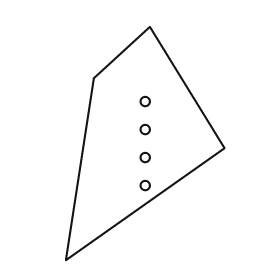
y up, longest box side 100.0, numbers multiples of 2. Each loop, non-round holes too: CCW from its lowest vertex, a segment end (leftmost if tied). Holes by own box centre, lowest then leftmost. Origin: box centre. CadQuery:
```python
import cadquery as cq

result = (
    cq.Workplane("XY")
    .moveTo(-34.0, -50.0)
    .lineTo(34.0, -2.0)
    .lineTo(2.0, 50.0)
    .lineTo(-22.0, 28.0)
    .close()
    .moveTo(0.0, -18.0)
    .circle(2.0)
    .moveTo(0.0, -6.0)
    .circle(2.0)
    .moveTo(0.0, 6.0)
    .circle(2.0)
    .moveTo(0.0, 18.0)
    .circle(2.0)
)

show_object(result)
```